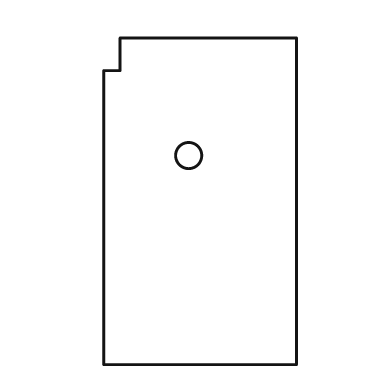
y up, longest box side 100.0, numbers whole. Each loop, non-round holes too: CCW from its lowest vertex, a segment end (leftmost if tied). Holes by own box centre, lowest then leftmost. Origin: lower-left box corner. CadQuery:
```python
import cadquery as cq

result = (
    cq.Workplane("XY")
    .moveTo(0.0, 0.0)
    .lineTo(59.0, 0.0)
    .lineTo(59.0, 100.0)
    .lineTo(5.0, 100.0)
    .lineTo(5.0, 90.0)
    .lineTo(0.0, 90.0)
    .close()
    .moveTo(26.0, 64.0)
    .circle(4.0)
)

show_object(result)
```